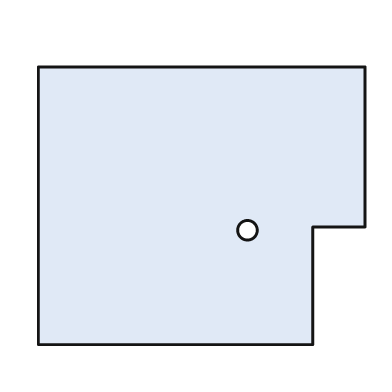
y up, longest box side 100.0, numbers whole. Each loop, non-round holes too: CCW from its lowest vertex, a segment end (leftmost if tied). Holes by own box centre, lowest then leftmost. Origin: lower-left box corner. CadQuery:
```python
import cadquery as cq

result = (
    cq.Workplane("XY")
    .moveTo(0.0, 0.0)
    .lineTo(84.0, 0.0)
    .lineTo(84.0, 36.0)
    .lineTo(100.0, 36.0)
    .lineTo(100.0, 85.0)
    .lineTo(0.0, 85.0)
    .close()
    .moveTo(64.0, 35.0)
    .circle(3.0)
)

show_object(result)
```